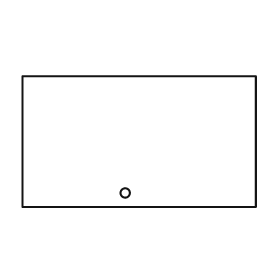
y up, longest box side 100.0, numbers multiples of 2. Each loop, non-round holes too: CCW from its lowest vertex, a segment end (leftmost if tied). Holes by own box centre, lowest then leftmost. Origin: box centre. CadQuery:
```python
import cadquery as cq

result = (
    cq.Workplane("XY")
    .moveTo(-50.0, -28.0)
    .lineTo(50.0, -28.0)
    .lineTo(50.0, 28.0)
    .lineTo(-50.0, 28.0)
    .close()
    .moveTo(-6.0, -22.0)
    .circle(2.0)
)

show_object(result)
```